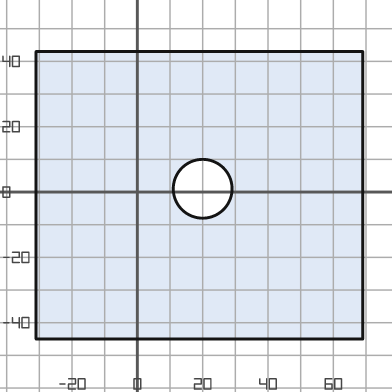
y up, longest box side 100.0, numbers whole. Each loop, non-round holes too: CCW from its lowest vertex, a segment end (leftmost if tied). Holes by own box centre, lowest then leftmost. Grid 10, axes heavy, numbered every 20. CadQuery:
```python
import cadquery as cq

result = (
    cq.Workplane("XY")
    .moveTo(-31.0, -45.0)
    .lineTo(69.0, -45.0)
    .lineTo(69.0, 43.0)
    .lineTo(-31.0, 43.0)
    .close()
    .moveTo(20.0, 1.0)
    .circle(9.0)
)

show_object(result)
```